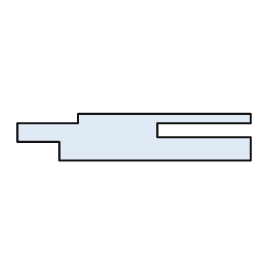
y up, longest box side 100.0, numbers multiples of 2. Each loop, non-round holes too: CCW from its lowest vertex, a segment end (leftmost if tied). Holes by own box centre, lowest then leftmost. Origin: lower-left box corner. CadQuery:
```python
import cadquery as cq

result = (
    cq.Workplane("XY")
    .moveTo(18.0, 0.0)
    .lineTo(100.0, 0.0)
    .lineTo(100.0, 10.0)
    .lineTo(60.0, 10.0)
    .lineTo(60.0, 16.0)
    .lineTo(100.0, 16.0)
    .lineTo(100.0, 20.0)
    .lineTo(26.0, 20.0)
    .lineTo(26.0, 16.0)
    .lineTo(0.0, 16.0)
    .lineTo(0.0, 8.0)
    .lineTo(18.0, 8.0)
    .close()
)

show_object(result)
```